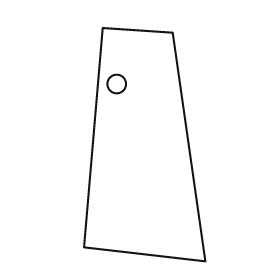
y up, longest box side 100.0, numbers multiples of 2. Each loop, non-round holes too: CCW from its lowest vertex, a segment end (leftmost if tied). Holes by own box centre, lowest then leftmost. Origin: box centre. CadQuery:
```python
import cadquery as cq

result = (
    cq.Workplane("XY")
    .moveTo(26.0, -50.0)
    .lineTo(12.0, 48.0)
    .lineTo(-18.0, 50.0)
    .lineTo(-26.0, -44.0)
    .close()
    .moveTo(-12.0, 26.0)
    .circle(4.0)
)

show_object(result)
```